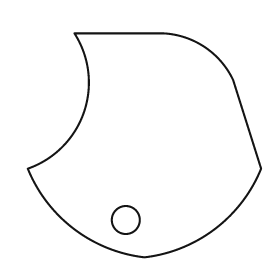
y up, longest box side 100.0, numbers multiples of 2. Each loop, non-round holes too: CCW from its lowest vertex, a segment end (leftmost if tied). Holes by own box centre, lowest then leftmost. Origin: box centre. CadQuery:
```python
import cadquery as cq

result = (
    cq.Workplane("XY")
    .moveTo(0.0, -48.0)
    .threePointArc((30.0, -36.0), (50.0, -10.0))
    .lineTo(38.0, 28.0)
    .threePointArc((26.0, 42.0), (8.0, 48.0))
    .lineTo(-30.0, 48.0)
    .threePointArc((-26.0, 14.0), (-50.0, -10.0))
    .threePointArc((-30.0, -36.0), (0.0, -48.0))
    .close()
    .moveTo(-8.0, -32.0)
    .circle(6.0)
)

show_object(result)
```